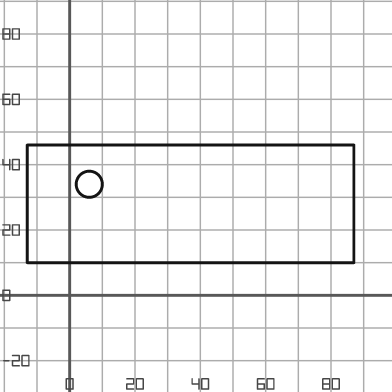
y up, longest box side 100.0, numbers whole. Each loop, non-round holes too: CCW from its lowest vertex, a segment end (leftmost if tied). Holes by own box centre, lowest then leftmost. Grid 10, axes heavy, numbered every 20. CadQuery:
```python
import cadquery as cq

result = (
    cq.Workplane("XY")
    .moveTo(-13.0, 10.0)
    .lineTo(87.0, 10.0)
    .lineTo(87.0, 46.0)
    .lineTo(-13.0, 46.0)
    .close()
    .moveTo(6.0, 34.0)
    .circle(4.0)
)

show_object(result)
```